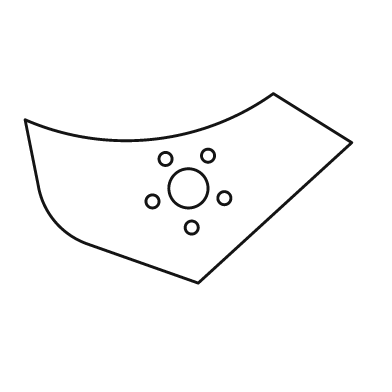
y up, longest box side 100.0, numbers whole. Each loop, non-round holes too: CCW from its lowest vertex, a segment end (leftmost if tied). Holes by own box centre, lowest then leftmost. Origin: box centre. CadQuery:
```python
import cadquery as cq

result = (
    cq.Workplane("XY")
    .moveTo(3.0, -29.0)
    .lineTo(50.0, 14.0)
    .lineTo(26.0, 29.0)
    .threePointArc((-11.0, 15.0), (-50.0, 21.0))
    .lineTo(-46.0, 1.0)
    .threePointArc((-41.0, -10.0), (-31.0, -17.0))
    .close()
    .moveTo(1.0, -12.0)
    .circle(2.0)
    .moveTo(-11.0, -4.0)
    .circle(2.0)
    .moveTo(11.0, -3.0)
    .circle(2.0)
    .moveTo(0.0, 0.0)
    .circle(6.0)
    .moveTo(-7.0, 9.0)
    .circle(2.0)
    .moveTo(6.0, 10.0)
    .circle(2.0)
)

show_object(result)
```